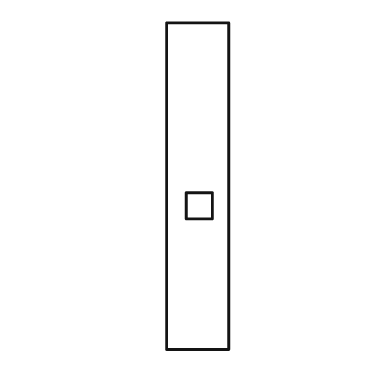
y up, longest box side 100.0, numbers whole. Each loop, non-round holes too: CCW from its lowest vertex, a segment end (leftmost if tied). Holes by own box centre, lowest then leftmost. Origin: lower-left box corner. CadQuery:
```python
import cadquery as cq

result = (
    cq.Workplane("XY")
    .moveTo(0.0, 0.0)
    .lineTo(19.0, 0.0)
    .lineTo(19.0, 100.0)
    .lineTo(0.0, 100.0)
    .close()
    .moveTo(6.0, 40.0)
    .lineTo(14.0, 40.0)
    .lineTo(14.0, 48.0)
    .lineTo(6.0, 48.0)
    .close()
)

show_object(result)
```